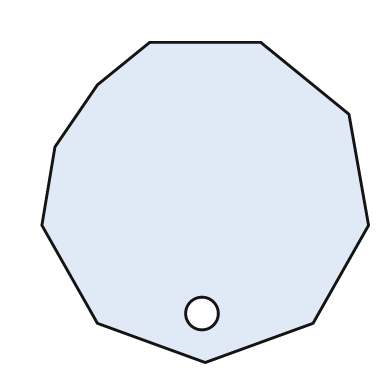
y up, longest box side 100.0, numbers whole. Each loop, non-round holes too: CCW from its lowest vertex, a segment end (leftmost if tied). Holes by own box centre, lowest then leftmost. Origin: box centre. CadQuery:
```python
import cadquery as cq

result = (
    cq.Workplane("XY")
    .moveTo(0.0, -49.0)
    .lineTo(33.0, -37.0)
    .lineTo(50.0, -7.0)
    .lineTo(44.0, 27.0)
    .lineTo(17.0, 49.0)
    .lineTo(-17.0, 49.0)
    .lineTo(-33.0, 36.0)
    .lineTo(-46.0, 17.0)
    .lineTo(-50.0, -7.0)
    .lineTo(-33.0, -37.0)
    .close()
    .moveTo(-1.0, -34.0)
    .circle(5.0)
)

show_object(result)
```